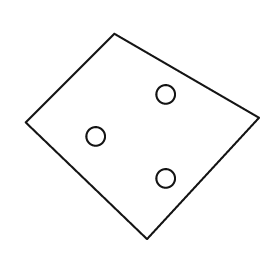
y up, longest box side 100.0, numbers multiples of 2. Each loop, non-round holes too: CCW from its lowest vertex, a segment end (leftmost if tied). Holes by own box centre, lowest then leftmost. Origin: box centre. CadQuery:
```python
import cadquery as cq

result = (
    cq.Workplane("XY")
    .moveTo(2.0, -44.0)
    .lineTo(50.0, 8.0)
    .lineTo(-12.0, 44.0)
    .lineTo(-50.0, 6.0)
    .close()
    .moveTo(10.0, -18.0)
    .circle(4.0)
    .moveTo(-20.0, 0.0)
    .circle(4.0)
    .moveTo(10.0, 18.0)
    .circle(4.0)
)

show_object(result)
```